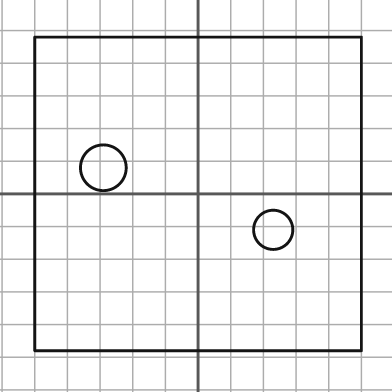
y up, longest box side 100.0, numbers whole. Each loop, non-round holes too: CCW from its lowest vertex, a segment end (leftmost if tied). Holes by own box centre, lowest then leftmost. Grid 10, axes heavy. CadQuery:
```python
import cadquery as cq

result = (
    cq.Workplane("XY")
    .moveTo(-50.0, -48.0)
    .lineTo(50.0, -48.0)
    .lineTo(50.0, 48.0)
    .lineTo(-50.0, 48.0)
    .close()
    .moveTo(23.0, -11.0)
    .circle(6.0)
    .moveTo(-29.0, 8.0)
    .circle(7.0)
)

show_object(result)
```